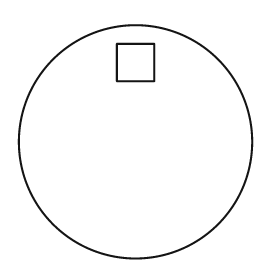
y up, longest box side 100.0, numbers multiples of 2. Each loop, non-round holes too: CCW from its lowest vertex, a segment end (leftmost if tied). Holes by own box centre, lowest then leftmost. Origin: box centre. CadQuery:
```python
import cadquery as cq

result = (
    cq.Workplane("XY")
    .moveTo(0.0, 0.0)
    .circle(50.0)
    .moveTo(-8.0, 26.0)
    .lineTo(8.0, 26.0)
    .lineTo(8.0, 42.0)
    .lineTo(-8.0, 42.0)
    .close()
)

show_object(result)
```